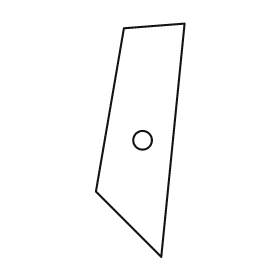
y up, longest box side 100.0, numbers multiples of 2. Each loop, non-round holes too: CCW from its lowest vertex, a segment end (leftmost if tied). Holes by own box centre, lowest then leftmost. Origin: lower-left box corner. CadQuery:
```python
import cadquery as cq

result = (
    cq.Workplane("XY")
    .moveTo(28.0, 0.0)
    .lineTo(38.0, 100.0)
    .lineTo(12.0, 98.0)
    .lineTo(0.0, 28.0)
    .close()
    .moveTo(20.0, 50.0)
    .circle(4.0)
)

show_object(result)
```